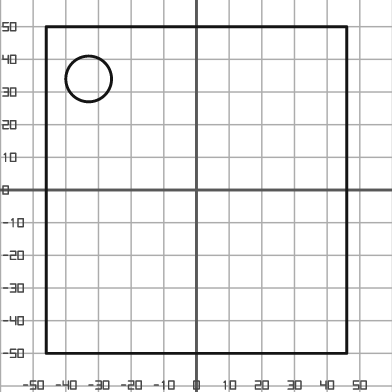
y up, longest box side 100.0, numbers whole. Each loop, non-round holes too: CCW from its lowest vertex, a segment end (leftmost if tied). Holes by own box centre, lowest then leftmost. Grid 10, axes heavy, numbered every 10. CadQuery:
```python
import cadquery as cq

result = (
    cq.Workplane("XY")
    .moveTo(-46.0, -50.0)
    .lineTo(46.0, -50.0)
    .lineTo(46.0, 50.0)
    .lineTo(-46.0, 50.0)
    .close()
    .moveTo(-33.0, 34.0)
    .circle(7.0)
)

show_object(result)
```